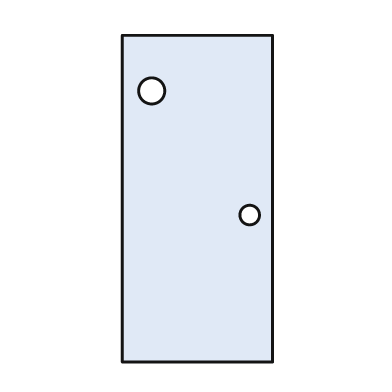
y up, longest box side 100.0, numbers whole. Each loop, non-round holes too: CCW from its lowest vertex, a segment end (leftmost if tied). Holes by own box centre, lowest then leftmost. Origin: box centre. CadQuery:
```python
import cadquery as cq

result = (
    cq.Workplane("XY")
    .moveTo(-23.0, -50.0)
    .lineTo(23.0, -50.0)
    .lineTo(23.0, 50.0)
    .lineTo(-23.0, 50.0)
    .close()
    .moveTo(16.0, -5.0)
    .circle(3.0)
    .moveTo(-14.0, 33.0)
    .circle(4.0)
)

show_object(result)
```